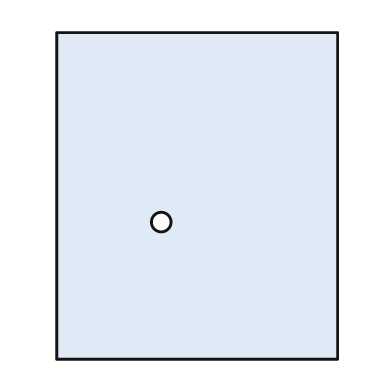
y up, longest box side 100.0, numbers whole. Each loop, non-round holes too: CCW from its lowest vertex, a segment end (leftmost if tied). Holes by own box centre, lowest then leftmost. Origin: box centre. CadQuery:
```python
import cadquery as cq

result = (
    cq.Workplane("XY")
    .moveTo(-43.0, -50.0)
    .lineTo(43.0, -50.0)
    .lineTo(43.0, 50.0)
    .lineTo(-43.0, 50.0)
    .close()
    .moveTo(-11.0, -8.0)
    .circle(3.0)
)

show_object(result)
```